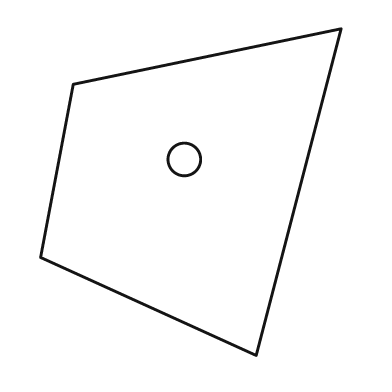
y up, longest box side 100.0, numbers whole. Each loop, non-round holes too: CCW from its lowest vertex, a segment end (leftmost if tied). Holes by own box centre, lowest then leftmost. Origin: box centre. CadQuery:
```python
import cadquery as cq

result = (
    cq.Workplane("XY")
    .moveTo(20.0, -50.0)
    .lineTo(46.0, 50.0)
    .lineTo(-36.0, 33.0)
    .lineTo(-46.0, -20.0)
    .close()
    .moveTo(-2.0, 10.0)
    .circle(5.0)
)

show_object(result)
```